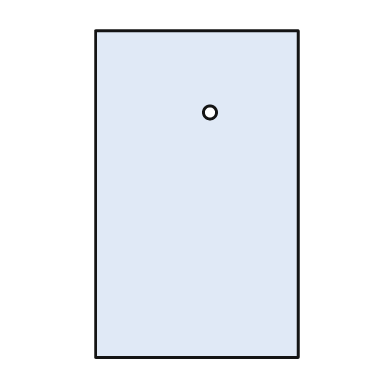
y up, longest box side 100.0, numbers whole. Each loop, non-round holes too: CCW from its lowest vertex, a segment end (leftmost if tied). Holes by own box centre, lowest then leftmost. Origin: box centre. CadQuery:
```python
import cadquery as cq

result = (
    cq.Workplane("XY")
    .moveTo(-31.0, -50.0)
    .lineTo(31.0, -50.0)
    .lineTo(31.0, 50.0)
    .lineTo(-31.0, 50.0)
    .close()
    .moveTo(4.0, 25.0)
    .circle(2.0)
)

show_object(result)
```